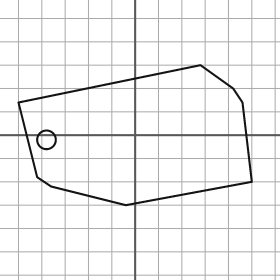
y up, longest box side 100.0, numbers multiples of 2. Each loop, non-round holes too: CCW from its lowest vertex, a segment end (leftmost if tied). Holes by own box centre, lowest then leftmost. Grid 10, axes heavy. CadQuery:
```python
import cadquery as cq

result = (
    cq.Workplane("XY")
    .moveTo(-4.0, -30.0)
    .lineTo(50.0, -20.0)
    .lineTo(46.0, 14.0)
    .lineTo(42.0, 20.0)
    .lineTo(28.0, 30.0)
    .lineTo(-50.0, 14.0)
    .lineTo(-42.0, -18.0)
    .lineTo(-36.0, -22.0)
    .close()
    .moveTo(-38.0, -2.0)
    .circle(4.0)
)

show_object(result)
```